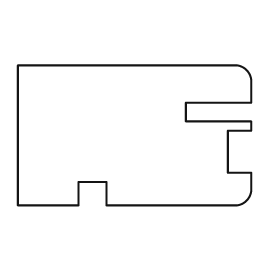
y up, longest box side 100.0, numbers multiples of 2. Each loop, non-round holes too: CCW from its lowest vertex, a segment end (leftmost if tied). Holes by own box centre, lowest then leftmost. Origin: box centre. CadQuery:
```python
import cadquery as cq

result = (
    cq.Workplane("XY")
    .moveTo(-50.0, -30.0)
    .lineTo(-24.0, -30.0)
    .lineTo(-24.0, -20.0)
    .lineTo(-12.0, -20.0)
    .lineTo(-12.0, -30.0)
    .lineTo(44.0, -30.0)
    .threePointArc((48.0, -28.0), (50.0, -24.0))
    .lineTo(50.0, -16.0)
    .lineTo(40.0, -16.0)
    .lineTo(40.0, 2.0)
    .lineTo(50.0, 2.0)
    .lineTo(50.0, 6.0)
    .lineTo(22.0, 6.0)
    .lineTo(22.0, 14.0)
    .lineTo(50.0, 14.0)
    .lineTo(50.0, 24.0)
    .threePointArc((48.0, 28.0), (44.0, 30.0))
    .lineTo(-50.0, 30.0)
    .close()
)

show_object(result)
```